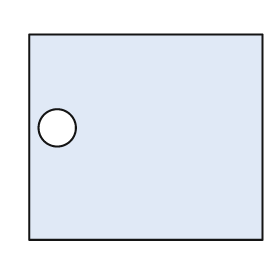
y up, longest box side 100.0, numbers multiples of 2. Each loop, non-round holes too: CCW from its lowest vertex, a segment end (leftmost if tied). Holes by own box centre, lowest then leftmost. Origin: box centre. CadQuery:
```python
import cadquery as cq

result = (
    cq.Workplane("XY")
    .moveTo(-50.0, -44.0)
    .lineTo(50.0, -44.0)
    .lineTo(50.0, 44.0)
    .lineTo(-50.0, 44.0)
    .close()
    .moveTo(-38.0, 4.0)
    .circle(8.0)
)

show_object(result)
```